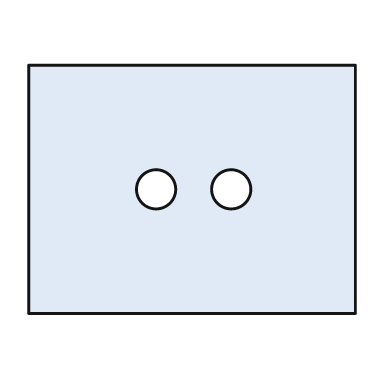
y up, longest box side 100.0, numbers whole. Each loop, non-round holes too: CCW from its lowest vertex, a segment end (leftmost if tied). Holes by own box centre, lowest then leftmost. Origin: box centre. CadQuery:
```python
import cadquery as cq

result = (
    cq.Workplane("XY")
    .moveTo(-50.0, -38.0)
    .lineTo(50.0, -38.0)
    .lineTo(50.0, 38.0)
    .lineTo(-50.0, 38.0)
    .close()
    .moveTo(-11.0, 0.0)
    .circle(6.0)
    .moveTo(12.0, 0.0)
    .circle(6.0)
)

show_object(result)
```